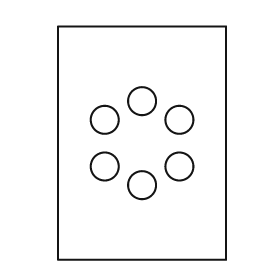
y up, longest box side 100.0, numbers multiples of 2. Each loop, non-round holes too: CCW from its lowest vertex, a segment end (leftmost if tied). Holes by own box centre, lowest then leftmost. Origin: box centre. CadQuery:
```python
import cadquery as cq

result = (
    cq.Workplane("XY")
    .moveTo(-36.0, -50.0)
    .lineTo(36.0, -50.0)
    .lineTo(36.0, 50.0)
    .lineTo(-36.0, 50.0)
    .close()
    .moveTo(0.0, -18.0)
    .circle(6.0)
    .moveTo(-16.0, -10.0)
    .circle(6.0)
    .moveTo(16.0, -10.0)
    .circle(6.0)
    .moveTo(-16.0, 10.0)
    .circle(6.0)
    .moveTo(16.0, 10.0)
    .circle(6.0)
    .moveTo(0.0, 18.0)
    .circle(6.0)
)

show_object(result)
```